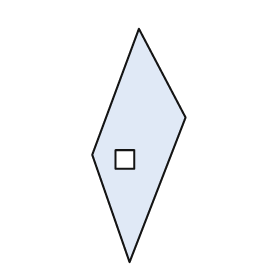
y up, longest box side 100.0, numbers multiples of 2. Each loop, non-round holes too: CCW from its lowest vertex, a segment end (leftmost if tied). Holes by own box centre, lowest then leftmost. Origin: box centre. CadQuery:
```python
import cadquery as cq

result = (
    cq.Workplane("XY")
    .moveTo(-4.0, -50.0)
    .lineTo(20.0, 12.0)
    .lineTo(0.0, 50.0)
    .lineTo(-20.0, -4.0)
    .close()
    .moveTo(-10.0, -10.0)
    .lineTo(-2.0, -10.0)
    .lineTo(-2.0, -2.0)
    .lineTo(-10.0, -2.0)
    .close()
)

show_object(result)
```